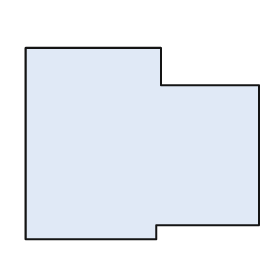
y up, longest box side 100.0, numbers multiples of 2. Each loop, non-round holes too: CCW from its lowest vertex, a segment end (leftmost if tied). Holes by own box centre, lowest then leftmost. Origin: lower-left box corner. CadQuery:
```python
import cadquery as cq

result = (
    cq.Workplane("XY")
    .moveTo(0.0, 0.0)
    .lineTo(56.0, 0.0)
    .lineTo(56.0, 6.0)
    .lineTo(100.0, 6.0)
    .lineTo(100.0, 66.0)
    .lineTo(58.0, 66.0)
    .lineTo(58.0, 82.0)
    .lineTo(0.0, 82.0)
    .close()
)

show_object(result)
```